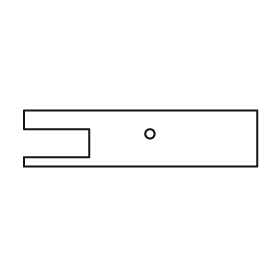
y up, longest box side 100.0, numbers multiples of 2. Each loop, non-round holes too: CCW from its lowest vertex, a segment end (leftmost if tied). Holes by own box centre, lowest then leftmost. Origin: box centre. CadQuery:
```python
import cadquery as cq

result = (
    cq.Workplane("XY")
    .moveTo(-50.0, -12.0)
    .lineTo(50.0, -12.0)
    .lineTo(50.0, 12.0)
    .lineTo(-50.0, 12.0)
    .lineTo(-50.0, 4.0)
    .lineTo(-22.0, 4.0)
    .lineTo(-22.0, -8.0)
    .lineTo(-50.0, -8.0)
    .close()
    .moveTo(4.0, 2.0)
    .circle(2.0)
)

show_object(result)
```